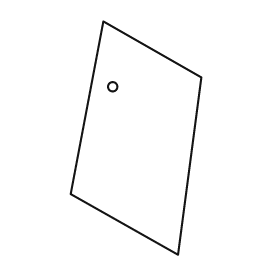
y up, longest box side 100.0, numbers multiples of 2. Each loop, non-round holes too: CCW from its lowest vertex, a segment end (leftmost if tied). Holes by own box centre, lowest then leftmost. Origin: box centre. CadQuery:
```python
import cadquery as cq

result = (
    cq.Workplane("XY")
    .moveTo(18.0, -50.0)
    .lineTo(28.0, 26.0)
    .lineTo(-14.0, 50.0)
    .lineTo(-28.0, -24.0)
    .close()
    .moveTo(-10.0, 22.0)
    .circle(2.0)
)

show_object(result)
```